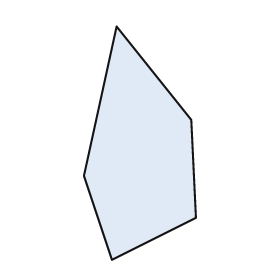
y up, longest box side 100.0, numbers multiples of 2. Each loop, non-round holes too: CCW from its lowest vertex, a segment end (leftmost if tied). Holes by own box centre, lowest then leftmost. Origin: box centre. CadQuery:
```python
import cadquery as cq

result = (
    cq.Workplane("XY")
    .moveTo(-12.0, -50.0)
    .lineTo(24.0, -32.0)
    .lineTo(22.0, 10.0)
    .lineTo(-10.0, 50.0)
    .lineTo(-24.0, -14.0)
    .close()
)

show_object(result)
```